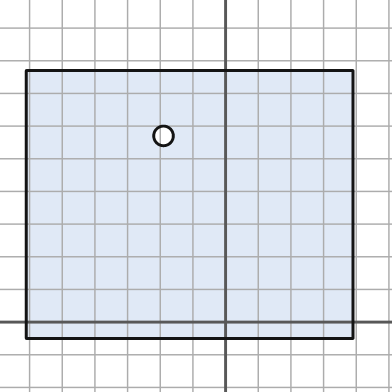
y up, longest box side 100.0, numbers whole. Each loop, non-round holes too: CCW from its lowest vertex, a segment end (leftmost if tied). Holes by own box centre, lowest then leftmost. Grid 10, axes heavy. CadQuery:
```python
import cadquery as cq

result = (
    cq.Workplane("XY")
    .moveTo(-61.0, -5.0)
    .lineTo(39.0, -5.0)
    .lineTo(39.0, 77.0)
    .lineTo(-61.0, 77.0)
    .close()
    .moveTo(-19.0, 57.0)
    .circle(3.0)
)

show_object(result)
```